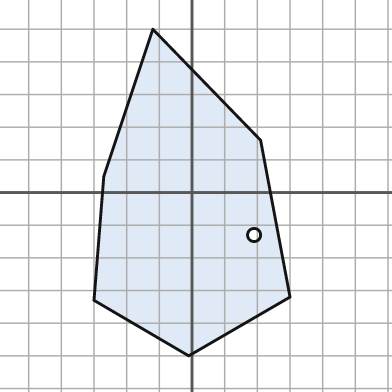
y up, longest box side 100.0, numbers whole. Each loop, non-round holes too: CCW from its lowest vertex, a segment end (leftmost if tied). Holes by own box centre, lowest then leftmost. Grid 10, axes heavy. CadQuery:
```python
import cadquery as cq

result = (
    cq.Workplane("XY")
    .moveTo(-1.0, -50.0)
    .lineTo(30.0, -32.0)
    .lineTo(21.0, 16.0)
    .lineTo(-12.0, 50.0)
    .lineTo(-27.0, 5.0)
    .lineTo(-30.0, -33.0)
    .close()
    .moveTo(19.0, -13.0)
    .circle(2.0)
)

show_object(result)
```